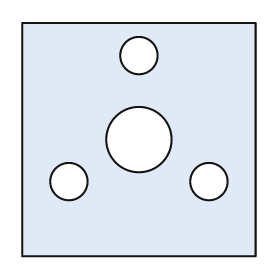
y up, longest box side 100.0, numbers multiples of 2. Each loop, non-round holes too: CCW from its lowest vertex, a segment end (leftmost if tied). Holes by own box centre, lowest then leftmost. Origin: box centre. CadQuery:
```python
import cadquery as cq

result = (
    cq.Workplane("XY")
    .moveTo(-50.0, -50.0)
    .lineTo(50.0, -50.0)
    .lineTo(50.0, 50.0)
    .lineTo(-50.0, 50.0)
    .close()
    .moveTo(-30.0, -18.0)
    .circle(8.0)
    .moveTo(30.0, -18.0)
    .circle(8.0)
    .moveTo(0.0, 0.0)
    .circle(14.0)
    .moveTo(0.0, 36.0)
    .circle(8.0)
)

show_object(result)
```